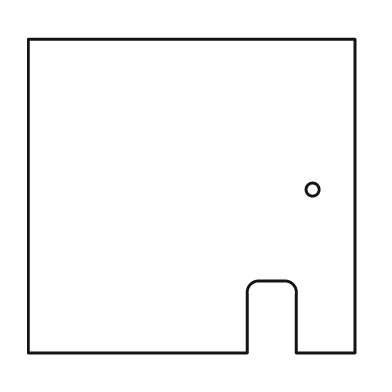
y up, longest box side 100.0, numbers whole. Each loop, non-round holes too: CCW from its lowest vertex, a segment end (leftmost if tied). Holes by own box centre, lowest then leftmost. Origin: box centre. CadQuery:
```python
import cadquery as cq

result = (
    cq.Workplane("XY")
    .moveTo(-50.0, -48.0)
    .lineTo(17.0, -48.0)
    .lineTo(17.0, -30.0)
    .threePointArc((18.0, -27.0), (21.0, -26.0))
    .lineTo(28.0, -26.0)
    .threePointArc((31.0, -27.0), (32.0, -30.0))
    .lineTo(32.0, -48.0)
    .lineTo(50.0, -48.0)
    .lineTo(50.0, 48.0)
    .lineTo(-50.0, 48.0)
    .close()
    .moveTo(37.0, 2.0)
    .circle(2.0)
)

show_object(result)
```